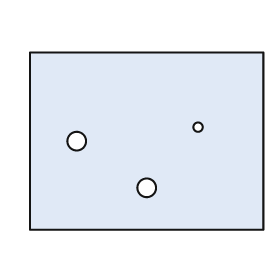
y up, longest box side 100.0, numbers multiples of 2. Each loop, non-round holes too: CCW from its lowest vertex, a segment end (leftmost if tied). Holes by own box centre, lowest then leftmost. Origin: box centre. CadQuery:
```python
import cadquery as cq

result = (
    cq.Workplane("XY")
    .moveTo(-50.0, -38.0)
    .lineTo(50.0, -38.0)
    .lineTo(50.0, 38.0)
    .lineTo(-50.0, 38.0)
    .close()
    .moveTo(0.0, -20.0)
    .circle(4.0)
    .moveTo(-30.0, 0.0)
    .circle(4.0)
    .moveTo(22.0, 6.0)
    .circle(2.0)
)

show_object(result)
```